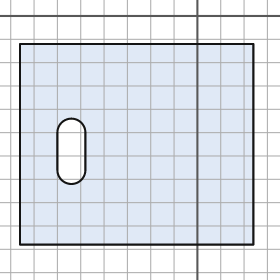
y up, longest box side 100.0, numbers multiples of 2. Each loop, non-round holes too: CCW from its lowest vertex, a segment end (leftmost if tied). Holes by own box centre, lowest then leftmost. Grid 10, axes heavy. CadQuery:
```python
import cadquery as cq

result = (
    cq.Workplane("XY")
    .moveTo(-76.0, -98.0)
    .lineTo(24.0, -98.0)
    .lineTo(24.0, -12.0)
    .lineTo(-76.0, -12.0)
    .close()
    .moveTo(-60.0, -66.0)
    .threePointArc((-54.0, -72.0), (-48.0, -66.0))
    .lineTo(-48.0, -50.0)
    .threePointArc((-54.0, -44.0), (-60.0, -50.0))
    .close()
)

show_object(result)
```